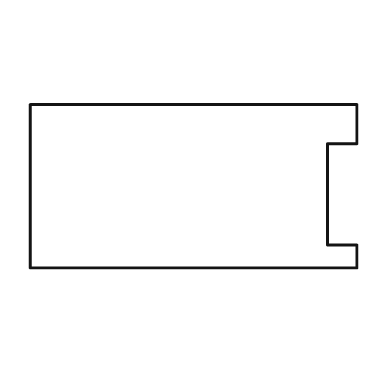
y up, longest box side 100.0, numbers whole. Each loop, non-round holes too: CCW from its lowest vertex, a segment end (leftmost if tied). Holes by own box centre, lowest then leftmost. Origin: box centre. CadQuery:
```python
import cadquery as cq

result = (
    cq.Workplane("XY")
    .moveTo(-50.0, -25.0)
    .lineTo(50.0, -25.0)
    .lineTo(50.0, -18.0)
    .lineTo(41.0, -18.0)
    .lineTo(41.0, 13.0)
    .lineTo(50.0, 13.0)
    .lineTo(50.0, 25.0)
    .lineTo(-50.0, 25.0)
    .close()
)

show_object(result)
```